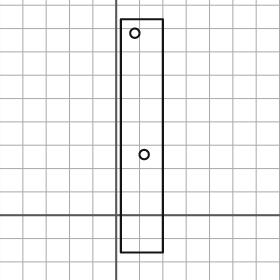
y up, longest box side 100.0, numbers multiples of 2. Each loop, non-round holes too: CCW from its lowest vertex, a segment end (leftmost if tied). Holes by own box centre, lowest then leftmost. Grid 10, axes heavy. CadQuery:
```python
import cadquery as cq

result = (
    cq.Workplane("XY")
    .moveTo(2.0, -16.0)
    .lineTo(20.0, -16.0)
    .lineTo(20.0, 84.0)
    .lineTo(2.0, 84.0)
    .close()
    .moveTo(12.0, 26.0)
    .circle(2.0)
    .moveTo(8.0, 78.0)
    .circle(2.0)
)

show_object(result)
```